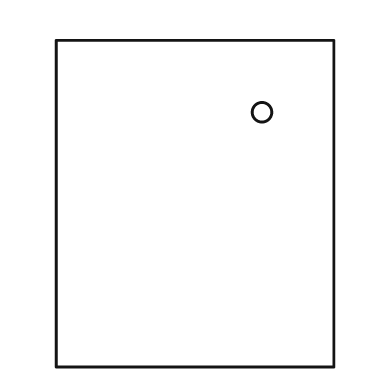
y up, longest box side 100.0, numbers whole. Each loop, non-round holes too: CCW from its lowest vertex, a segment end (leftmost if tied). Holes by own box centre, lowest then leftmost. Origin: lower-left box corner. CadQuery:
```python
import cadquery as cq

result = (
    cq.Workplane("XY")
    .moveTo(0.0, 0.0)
    .lineTo(85.0, 0.0)
    .lineTo(85.0, 100.0)
    .lineTo(0.0, 100.0)
    .close()
    .moveTo(63.0, 78.0)
    .circle(3.0)
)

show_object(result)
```